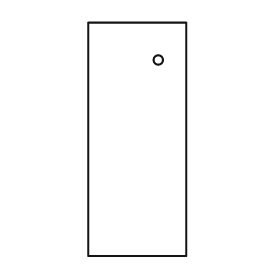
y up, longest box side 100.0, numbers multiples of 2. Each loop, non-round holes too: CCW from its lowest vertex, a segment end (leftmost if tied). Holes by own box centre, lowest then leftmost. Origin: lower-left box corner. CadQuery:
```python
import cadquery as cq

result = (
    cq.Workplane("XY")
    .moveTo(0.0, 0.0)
    .lineTo(42.0, 0.0)
    .lineTo(42.0, 100.0)
    .lineTo(0.0, 100.0)
    .close()
    .moveTo(30.0, 84.0)
    .circle(2.0)
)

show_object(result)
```